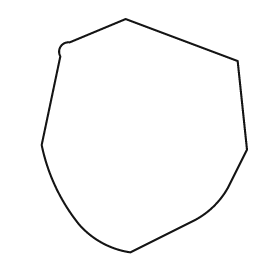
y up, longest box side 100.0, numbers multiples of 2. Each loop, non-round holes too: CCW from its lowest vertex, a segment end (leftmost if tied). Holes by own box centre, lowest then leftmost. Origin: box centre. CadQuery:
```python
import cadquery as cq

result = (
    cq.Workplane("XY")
    .moveTo(-6.0, -50.0)
    .lineTo(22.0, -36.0)
    .threePointArc((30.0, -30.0), (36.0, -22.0))
    .lineTo(44.0, -6.0)
    .lineTo(40.0, 32.0)
    .lineTo(-8.0, 50.0)
    .lineTo(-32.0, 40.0)
    .threePointArc((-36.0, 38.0), (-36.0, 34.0))
    .lineTo(-44.0, -4.0)
    .threePointArc((-38.0, -22.0), (-28.0, -38.0))
    .threePointArc((-18.0, -46.0), (-6.0, -50.0))
    .close()
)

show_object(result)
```